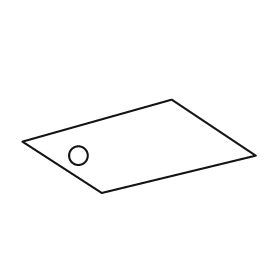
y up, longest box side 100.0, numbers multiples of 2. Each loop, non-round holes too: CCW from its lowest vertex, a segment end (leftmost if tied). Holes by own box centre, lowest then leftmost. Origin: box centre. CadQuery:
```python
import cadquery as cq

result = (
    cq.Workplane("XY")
    .moveTo(-16.0, -20.0)
    .lineTo(50.0, -4.0)
    .lineTo(14.0, 20.0)
    .lineTo(-50.0, 2.0)
    .close()
    .moveTo(-26.0, -4.0)
    .circle(4.0)
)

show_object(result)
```